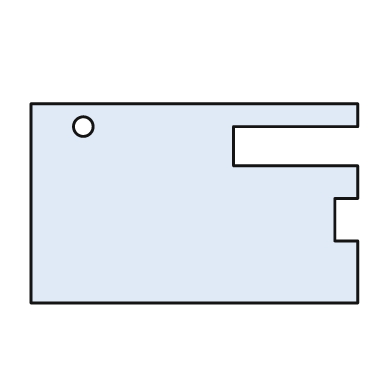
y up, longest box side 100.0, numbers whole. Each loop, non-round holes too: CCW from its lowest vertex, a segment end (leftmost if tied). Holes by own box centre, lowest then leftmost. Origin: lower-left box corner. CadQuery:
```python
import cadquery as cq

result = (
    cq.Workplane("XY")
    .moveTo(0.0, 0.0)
    .lineTo(100.0, 0.0)
    .lineTo(100.0, 19.0)
    .lineTo(93.0, 19.0)
    .lineTo(93.0, 32.0)
    .lineTo(100.0, 32.0)
    .lineTo(100.0, 42.0)
    .lineTo(62.0, 42.0)
    .lineTo(62.0, 54.0)
    .lineTo(100.0, 54.0)
    .lineTo(100.0, 61.0)
    .lineTo(0.0, 61.0)
    .close()
    .moveTo(16.0, 54.0)
    .circle(3.0)
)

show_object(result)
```